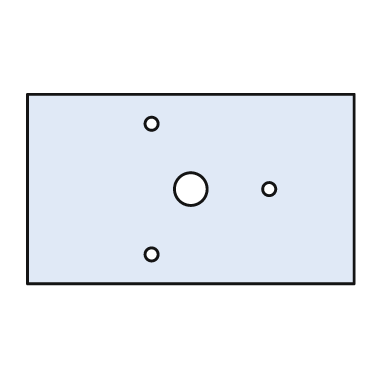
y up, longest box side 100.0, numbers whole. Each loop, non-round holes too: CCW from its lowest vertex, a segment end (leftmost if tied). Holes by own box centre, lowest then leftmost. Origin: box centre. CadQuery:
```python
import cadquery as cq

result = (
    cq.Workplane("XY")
    .moveTo(-50.0, -29.0)
    .lineTo(50.0, -29.0)
    .lineTo(50.0, 29.0)
    .lineTo(-50.0, 29.0)
    .close()
    .moveTo(-12.0, -20.0)
    .circle(2.0)
    .moveTo(0.0, 0.0)
    .circle(5.0)
    .moveTo(24.0, 0.0)
    .circle(2.0)
    .moveTo(-12.0, 20.0)
    .circle(2.0)
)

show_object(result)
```